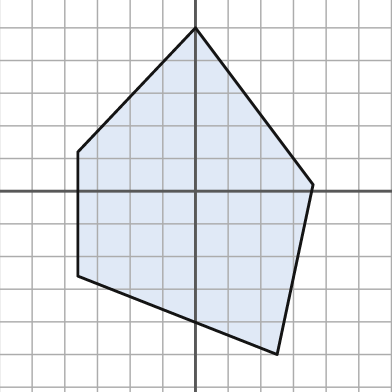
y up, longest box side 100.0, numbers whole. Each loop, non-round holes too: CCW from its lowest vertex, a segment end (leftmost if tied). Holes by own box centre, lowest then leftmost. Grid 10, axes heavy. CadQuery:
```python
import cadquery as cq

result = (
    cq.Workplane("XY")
    .moveTo(25.0, -50.0)
    .lineTo(36.0, 2.0)
    .lineTo(0.0, 50.0)
    .lineTo(-36.0, 12.0)
    .lineTo(-36.0, -26.0)
    .close()
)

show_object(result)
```